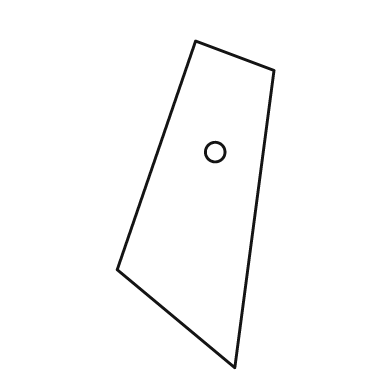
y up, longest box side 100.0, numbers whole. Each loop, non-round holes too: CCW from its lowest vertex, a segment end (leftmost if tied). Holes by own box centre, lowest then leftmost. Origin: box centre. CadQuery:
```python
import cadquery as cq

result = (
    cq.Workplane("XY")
    .moveTo(12.0, -50.0)
    .lineTo(24.0, 41.0)
    .lineTo(0.0, 50.0)
    .lineTo(-24.0, -20.0)
    .close()
    .moveTo(6.0, 16.0)
    .circle(3.0)
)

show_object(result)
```